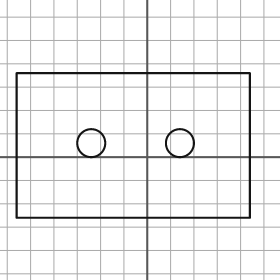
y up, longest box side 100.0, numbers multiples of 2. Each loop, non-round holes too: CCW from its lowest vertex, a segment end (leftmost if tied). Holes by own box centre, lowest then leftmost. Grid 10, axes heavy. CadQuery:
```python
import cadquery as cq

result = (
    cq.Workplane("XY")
    .moveTo(-56.0, -26.0)
    .lineTo(44.0, -26.0)
    .lineTo(44.0, 36.0)
    .lineTo(-56.0, 36.0)
    .close()
    .moveTo(-24.0, 6.0)
    .circle(6.0)
    .moveTo(14.0, 6.0)
    .circle(6.0)
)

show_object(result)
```